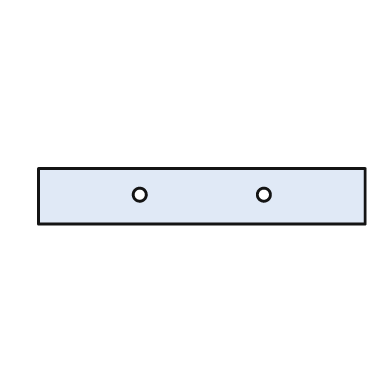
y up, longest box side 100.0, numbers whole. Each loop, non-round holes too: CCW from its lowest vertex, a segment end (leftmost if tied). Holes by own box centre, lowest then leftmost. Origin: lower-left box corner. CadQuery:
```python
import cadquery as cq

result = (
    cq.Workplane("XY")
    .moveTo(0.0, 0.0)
    .lineTo(100.0, 0.0)
    .lineTo(100.0, 17.0)
    .lineTo(0.0, 17.0)
    .close()
    .moveTo(31.0, 9.0)
    .circle(2.0)
    .moveTo(69.0, 9.0)
    .circle(2.0)
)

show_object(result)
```